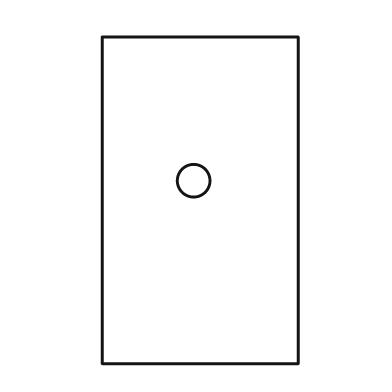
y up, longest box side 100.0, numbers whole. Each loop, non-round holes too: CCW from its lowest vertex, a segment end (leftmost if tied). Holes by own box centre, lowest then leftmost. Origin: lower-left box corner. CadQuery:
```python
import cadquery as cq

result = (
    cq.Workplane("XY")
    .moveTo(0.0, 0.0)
    .lineTo(60.0, 0.0)
    .lineTo(60.0, 100.0)
    .lineTo(0.0, 100.0)
    .close()
    .moveTo(28.0, 56.0)
    .circle(5.0)
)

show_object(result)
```